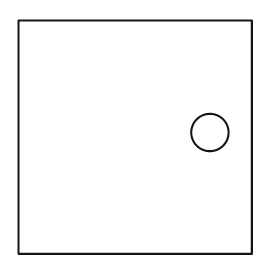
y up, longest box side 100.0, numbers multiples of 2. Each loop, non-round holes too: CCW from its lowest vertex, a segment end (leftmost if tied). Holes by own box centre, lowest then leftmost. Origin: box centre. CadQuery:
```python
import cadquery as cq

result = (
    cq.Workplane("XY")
    .moveTo(-50.0, -50.0)
    .lineTo(50.0, -50.0)
    .lineTo(50.0, 50.0)
    .lineTo(-50.0, 50.0)
    .close()
    .moveTo(32.0, 2.0)
    .circle(8.0)
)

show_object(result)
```